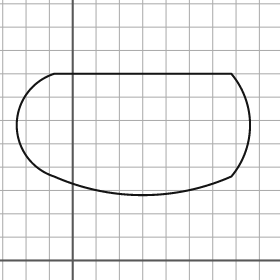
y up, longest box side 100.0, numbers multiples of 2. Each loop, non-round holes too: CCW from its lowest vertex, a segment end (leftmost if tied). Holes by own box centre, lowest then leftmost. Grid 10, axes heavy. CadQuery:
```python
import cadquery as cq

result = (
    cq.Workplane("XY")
    .moveTo(-8.0, 36.0)
    .threePointArc((30.0, 28.0), (68.0, 36.0))
    .threePointArc((76.0, 58.0), (68.0, 80.0))
    .lineTo(-8.0, 80.0)
    .threePointArc((-24.0, 58.0), (-8.0, 36.0))
    .close()
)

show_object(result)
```